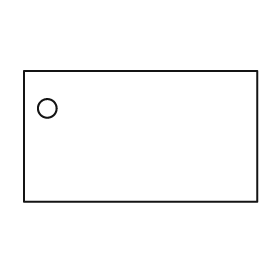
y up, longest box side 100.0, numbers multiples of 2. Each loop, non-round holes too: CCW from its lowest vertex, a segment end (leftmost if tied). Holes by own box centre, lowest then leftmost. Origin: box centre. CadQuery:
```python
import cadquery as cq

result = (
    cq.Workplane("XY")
    .moveTo(-50.0, -28.0)
    .lineTo(50.0, -28.0)
    .lineTo(50.0, 28.0)
    .lineTo(-50.0, 28.0)
    .close()
    .moveTo(-40.0, 12.0)
    .circle(4.0)
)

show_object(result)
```